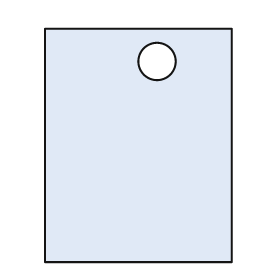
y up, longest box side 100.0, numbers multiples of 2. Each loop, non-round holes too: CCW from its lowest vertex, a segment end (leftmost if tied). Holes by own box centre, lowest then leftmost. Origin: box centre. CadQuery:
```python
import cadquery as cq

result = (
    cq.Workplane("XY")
    .moveTo(-40.0, -50.0)
    .lineTo(40.0, -50.0)
    .lineTo(40.0, 50.0)
    .lineTo(-40.0, 50.0)
    .close()
    .moveTo(8.0, 36.0)
    .circle(8.0)
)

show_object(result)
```